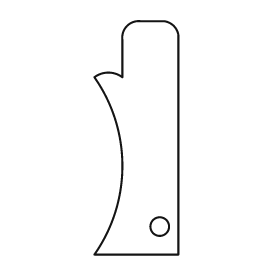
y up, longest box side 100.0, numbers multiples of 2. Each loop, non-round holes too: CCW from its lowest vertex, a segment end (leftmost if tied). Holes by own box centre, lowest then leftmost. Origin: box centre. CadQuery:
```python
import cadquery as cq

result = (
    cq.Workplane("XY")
    .moveTo(-18.0, -50.0)
    .lineTo(18.0, -50.0)
    .lineTo(18.0, 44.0)
    .threePointArc((16.0, 48.0), (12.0, 50.0))
    .lineTo(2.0, 50.0)
    .threePointArc((-4.0, 48.0), (-6.0, 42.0))
    .lineTo(-6.0, 26.0)
    .threePointArc((-12.0, 28.0), (-18.0, 26.0))
    .threePointArc((-6.0, -12.0), (-18.0, -50.0))
    .close()
    .moveTo(10.0, -38.0)
    .circle(4.0)
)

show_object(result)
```